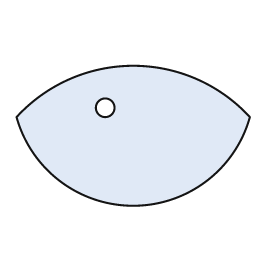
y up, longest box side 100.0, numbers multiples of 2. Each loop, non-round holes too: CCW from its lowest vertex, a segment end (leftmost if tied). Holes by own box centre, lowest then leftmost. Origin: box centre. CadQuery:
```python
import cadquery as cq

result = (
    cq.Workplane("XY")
    .moveTo(-50.0, 8.0)
    .threePointArc((0.0, -30.0), (50.0, 8.0))
    .threePointArc((0.0, 30.0), (-50.0, 8.0))
    .close()
    .moveTo(-12.0, 12.0)
    .circle(4.0)
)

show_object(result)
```